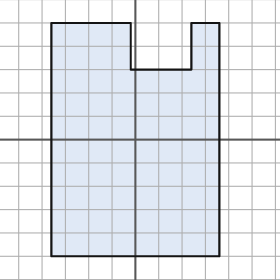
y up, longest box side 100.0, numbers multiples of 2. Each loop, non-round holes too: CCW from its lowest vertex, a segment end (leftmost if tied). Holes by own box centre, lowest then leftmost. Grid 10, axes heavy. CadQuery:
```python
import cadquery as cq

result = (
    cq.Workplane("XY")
    .moveTo(-36.0, -50.0)
    .lineTo(36.0, -50.0)
    .lineTo(36.0, 50.0)
    .lineTo(24.0, 50.0)
    .lineTo(24.0, 30.0)
    .lineTo(-2.0, 30.0)
    .lineTo(-2.0, 50.0)
    .lineTo(-36.0, 50.0)
    .close()
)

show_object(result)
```